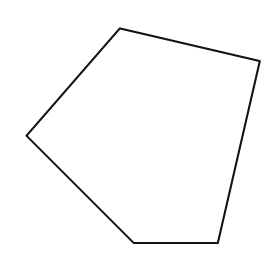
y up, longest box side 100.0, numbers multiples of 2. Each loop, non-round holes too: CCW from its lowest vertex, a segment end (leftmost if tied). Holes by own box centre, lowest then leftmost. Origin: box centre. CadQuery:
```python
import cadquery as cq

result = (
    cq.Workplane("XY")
    .moveTo(-4.0, -46.0)
    .lineTo(32.0, -46.0)
    .lineTo(50.0, 32.0)
    .lineTo(-10.0, 46.0)
    .lineTo(-50.0, 0.0)
    .close()
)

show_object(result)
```